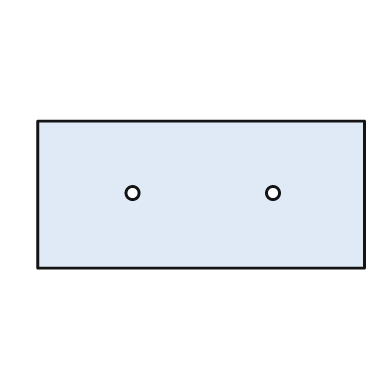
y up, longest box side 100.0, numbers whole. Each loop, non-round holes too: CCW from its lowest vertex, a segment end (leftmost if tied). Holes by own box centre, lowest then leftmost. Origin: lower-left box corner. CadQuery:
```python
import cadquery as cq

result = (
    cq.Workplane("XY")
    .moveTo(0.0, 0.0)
    .lineTo(100.0, 0.0)
    .lineTo(100.0, 45.0)
    .lineTo(0.0, 45.0)
    .close()
    .moveTo(29.0, 23.0)
    .circle(2.0)
    .moveTo(72.0, 23.0)
    .circle(2.0)
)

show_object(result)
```